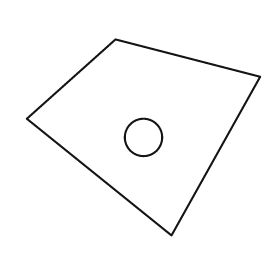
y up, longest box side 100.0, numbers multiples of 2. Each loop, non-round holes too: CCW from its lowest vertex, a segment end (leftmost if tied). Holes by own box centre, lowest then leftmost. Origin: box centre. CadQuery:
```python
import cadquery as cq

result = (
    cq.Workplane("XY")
    .moveTo(12.0, -42.0)
    .lineTo(50.0, 26.0)
    .lineTo(-12.0, 42.0)
    .lineTo(-50.0, 8.0)
    .close()
    .moveTo(0.0, 0.0)
    .circle(8.0)
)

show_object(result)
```